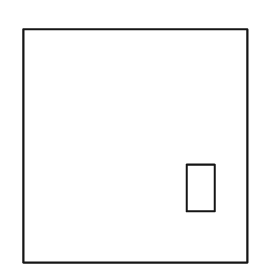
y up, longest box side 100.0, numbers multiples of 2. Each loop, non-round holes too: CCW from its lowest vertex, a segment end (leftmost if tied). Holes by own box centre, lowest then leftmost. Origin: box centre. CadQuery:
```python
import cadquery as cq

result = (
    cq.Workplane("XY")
    .moveTo(-48.0, -50.0)
    .lineTo(48.0, -50.0)
    .lineTo(48.0, 50.0)
    .lineTo(-48.0, 50.0)
    .close()
    .moveTo(22.0, -28.0)
    .lineTo(34.0, -28.0)
    .lineTo(34.0, -8.0)
    .lineTo(22.0, -8.0)
    .close()
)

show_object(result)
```